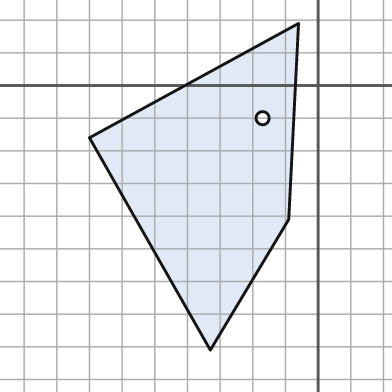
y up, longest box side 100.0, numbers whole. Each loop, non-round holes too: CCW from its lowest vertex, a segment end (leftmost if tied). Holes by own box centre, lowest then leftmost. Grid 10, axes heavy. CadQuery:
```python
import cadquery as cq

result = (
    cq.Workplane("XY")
    .moveTo(-33.0, -81.0)
    .lineTo(-9.0, -41.0)
    .lineTo(-6.0, 19.0)
    .lineTo(-70.0, -16.0)
    .close()
    .moveTo(-17.0, -10.0)
    .circle(2.0)
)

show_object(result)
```